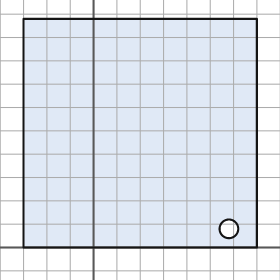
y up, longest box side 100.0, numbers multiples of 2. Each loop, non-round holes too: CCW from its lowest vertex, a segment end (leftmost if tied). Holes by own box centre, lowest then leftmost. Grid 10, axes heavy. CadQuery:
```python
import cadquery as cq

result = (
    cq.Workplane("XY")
    .moveTo(-30.0, 0.0)
    .lineTo(70.0, 0.0)
    .lineTo(70.0, 98.0)
    .lineTo(-30.0, 98.0)
    .close()
    .moveTo(58.0, 8.0)
    .circle(4.0)
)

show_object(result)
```